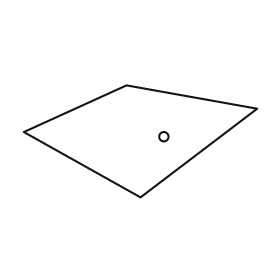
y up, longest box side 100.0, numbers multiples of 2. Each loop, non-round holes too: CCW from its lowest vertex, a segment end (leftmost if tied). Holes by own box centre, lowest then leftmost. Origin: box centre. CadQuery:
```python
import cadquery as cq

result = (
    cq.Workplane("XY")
    .moveTo(0.0, -24.0)
    .lineTo(50.0, 14.0)
    .lineTo(-6.0, 24.0)
    .lineTo(-50.0, 4.0)
    .close()
    .moveTo(10.0, 2.0)
    .circle(2.0)
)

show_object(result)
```